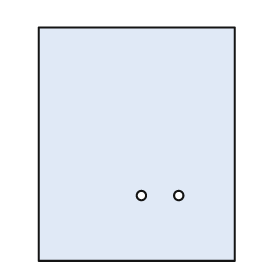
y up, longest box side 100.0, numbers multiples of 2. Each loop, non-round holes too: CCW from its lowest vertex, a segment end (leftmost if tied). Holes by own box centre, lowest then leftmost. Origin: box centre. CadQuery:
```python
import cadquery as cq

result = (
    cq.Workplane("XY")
    .moveTo(-42.0, -50.0)
    .lineTo(42.0, -50.0)
    .lineTo(42.0, 50.0)
    .lineTo(-42.0, 50.0)
    .close()
    .moveTo(2.0, -22.0)
    .circle(2.0)
    .moveTo(18.0, -22.0)
    .circle(2.0)
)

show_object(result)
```